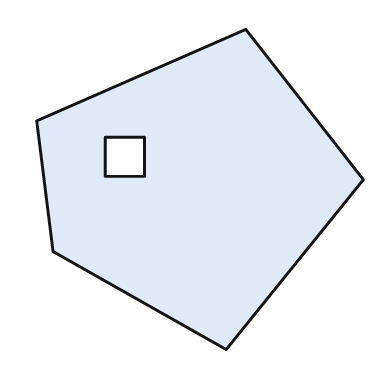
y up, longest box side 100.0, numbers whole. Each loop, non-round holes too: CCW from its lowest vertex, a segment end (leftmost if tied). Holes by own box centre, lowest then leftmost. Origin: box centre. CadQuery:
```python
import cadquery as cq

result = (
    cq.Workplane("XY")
    .moveTo(8.0, -49.0)
    .lineTo(50.0, 3.0)
    .lineTo(14.0, 49.0)
    .lineTo(-50.0, 21.0)
    .lineTo(-45.0, -19.0)
    .close()
    .moveTo(-29.0, 4.0)
    .lineTo(-17.0, 4.0)
    .lineTo(-17.0, 16.0)
    .lineTo(-29.0, 16.0)
    .close()
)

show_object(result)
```